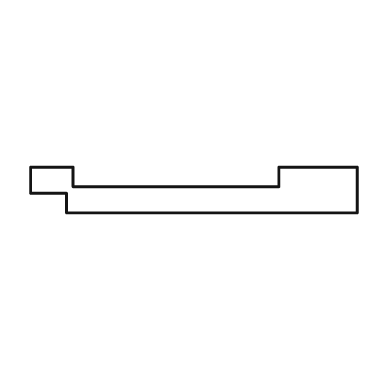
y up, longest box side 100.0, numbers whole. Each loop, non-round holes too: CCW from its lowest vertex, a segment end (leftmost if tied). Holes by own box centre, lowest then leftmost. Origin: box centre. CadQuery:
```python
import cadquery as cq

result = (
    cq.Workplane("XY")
    .moveTo(-39.0, -7.0)
    .lineTo(50.0, -7.0)
    .lineTo(50.0, 7.0)
    .lineTo(26.0, 7.0)
    .lineTo(26.0, 1.0)
    .lineTo(-37.0, 1.0)
    .lineTo(-37.0, 7.0)
    .lineTo(-50.0, 7.0)
    .lineTo(-50.0, -1.0)
    .lineTo(-39.0, -1.0)
    .close()
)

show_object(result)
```